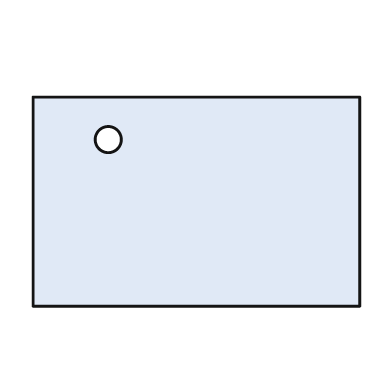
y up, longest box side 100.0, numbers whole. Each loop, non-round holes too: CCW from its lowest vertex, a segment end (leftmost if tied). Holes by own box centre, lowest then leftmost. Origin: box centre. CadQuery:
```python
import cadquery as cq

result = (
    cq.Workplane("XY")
    .moveTo(-50.0, -32.0)
    .lineTo(50.0, -32.0)
    .lineTo(50.0, 32.0)
    .lineTo(-50.0, 32.0)
    .close()
    .moveTo(-27.0, 19.0)
    .circle(4.0)
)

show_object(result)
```